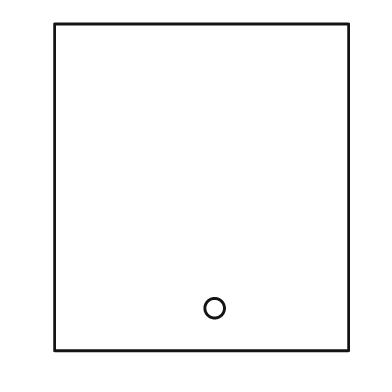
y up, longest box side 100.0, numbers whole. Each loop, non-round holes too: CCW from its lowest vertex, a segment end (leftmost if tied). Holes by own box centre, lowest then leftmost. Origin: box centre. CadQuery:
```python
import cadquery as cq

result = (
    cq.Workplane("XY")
    .moveTo(-45.0, -50.0)
    .lineTo(45.0, -50.0)
    .lineTo(45.0, 50.0)
    .lineTo(-45.0, 50.0)
    .close()
    .moveTo(4.0, -37.0)
    .circle(3.0)
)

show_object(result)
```